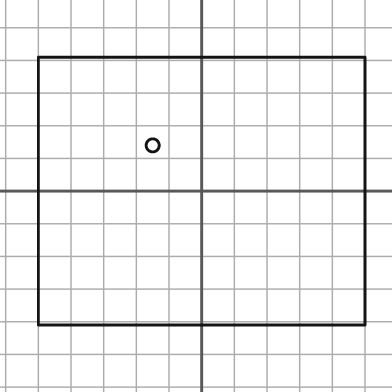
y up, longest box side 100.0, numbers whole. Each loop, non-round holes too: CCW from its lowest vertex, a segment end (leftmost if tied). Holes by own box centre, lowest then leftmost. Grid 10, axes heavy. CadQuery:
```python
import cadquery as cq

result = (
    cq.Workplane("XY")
    .moveTo(-50.0, -41.0)
    .lineTo(50.0, -41.0)
    .lineTo(50.0, 41.0)
    .lineTo(-50.0, 41.0)
    .close()
    .moveTo(-15.0, 14.0)
    .circle(2.0)
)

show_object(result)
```